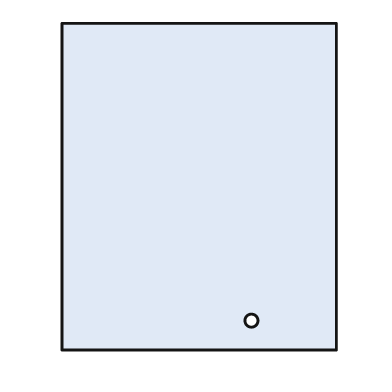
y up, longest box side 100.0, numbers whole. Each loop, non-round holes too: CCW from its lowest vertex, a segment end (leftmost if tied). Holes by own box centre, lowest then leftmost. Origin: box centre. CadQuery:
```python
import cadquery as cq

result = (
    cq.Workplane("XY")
    .moveTo(-42.0, -50.0)
    .lineTo(42.0, -50.0)
    .lineTo(42.0, 50.0)
    .lineTo(-42.0, 50.0)
    .close()
    .moveTo(16.0, -41.0)
    .circle(2.0)
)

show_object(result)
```